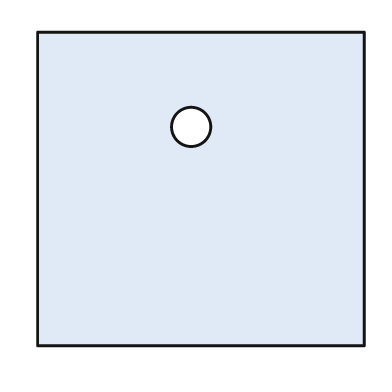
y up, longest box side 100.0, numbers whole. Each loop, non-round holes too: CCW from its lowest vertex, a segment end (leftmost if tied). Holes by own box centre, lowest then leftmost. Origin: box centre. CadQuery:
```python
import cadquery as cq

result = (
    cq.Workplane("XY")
    .moveTo(-50.0, -48.0)
    .lineTo(50.0, -48.0)
    .lineTo(50.0, 48.0)
    .lineTo(-50.0, 48.0)
    .close()
    .moveTo(-3.0, 19.0)
    .circle(6.0)
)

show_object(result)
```